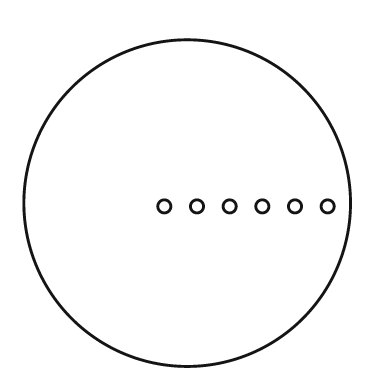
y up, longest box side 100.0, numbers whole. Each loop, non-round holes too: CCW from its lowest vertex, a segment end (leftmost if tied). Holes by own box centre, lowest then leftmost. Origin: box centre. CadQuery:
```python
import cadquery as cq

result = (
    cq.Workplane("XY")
    .moveTo(0.0, 0.0)
    .circle(50.0)
    .moveTo(-7.0, -1.0)
    .circle(2.0)
    .moveTo(3.0, -1.0)
    .circle(2.0)
    .moveTo(13.0, -1.0)
    .circle(2.0)
    .moveTo(23.0, -1.0)
    .circle(2.0)
    .moveTo(33.0, -1.0)
    .circle(2.0)
    .moveTo(43.0, -1.0)
    .circle(2.0)
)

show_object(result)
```